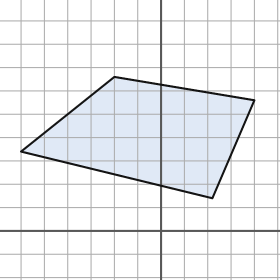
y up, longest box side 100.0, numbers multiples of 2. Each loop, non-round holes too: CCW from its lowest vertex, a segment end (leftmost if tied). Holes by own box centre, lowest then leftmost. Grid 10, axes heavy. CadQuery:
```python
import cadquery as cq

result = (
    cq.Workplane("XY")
    .moveTo(22.0, 14.0)
    .lineTo(40.0, 56.0)
    .lineTo(-20.0, 66.0)
    .lineTo(-60.0, 34.0)
    .close()
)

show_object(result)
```